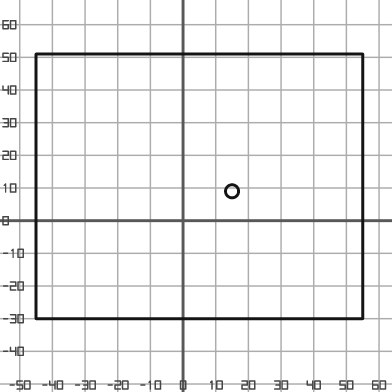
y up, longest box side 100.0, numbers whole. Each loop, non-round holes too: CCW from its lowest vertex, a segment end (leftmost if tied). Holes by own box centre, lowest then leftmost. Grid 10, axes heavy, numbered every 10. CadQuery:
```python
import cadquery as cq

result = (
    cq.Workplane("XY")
    .moveTo(-45.0, -30.0)
    .lineTo(55.0, -30.0)
    .lineTo(55.0, 51.0)
    .lineTo(-45.0, 51.0)
    .close()
    .moveTo(15.0, 9.0)
    .circle(2.0)
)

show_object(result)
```